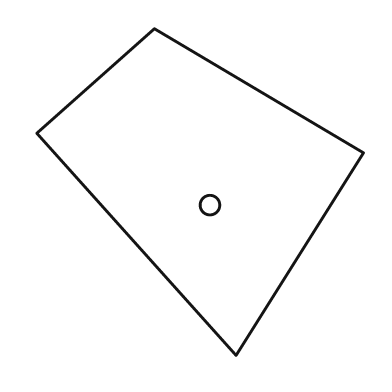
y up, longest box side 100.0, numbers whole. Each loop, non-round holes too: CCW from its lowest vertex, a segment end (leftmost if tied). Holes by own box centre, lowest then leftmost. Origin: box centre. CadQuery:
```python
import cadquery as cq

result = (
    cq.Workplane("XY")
    .moveTo(11.0, -50.0)
    .lineTo(50.0, 12.0)
    .lineTo(-14.0, 50.0)
    .lineTo(-50.0, 18.0)
    .close()
    .moveTo(3.0, -4.0)
    .circle(3.0)
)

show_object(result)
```